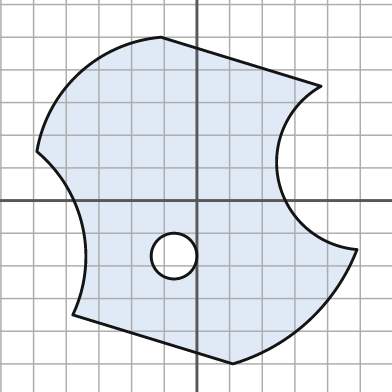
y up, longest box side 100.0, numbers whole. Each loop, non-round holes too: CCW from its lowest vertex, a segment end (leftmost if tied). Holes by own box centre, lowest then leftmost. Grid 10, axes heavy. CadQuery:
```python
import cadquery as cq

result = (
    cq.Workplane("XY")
    .moveTo(11.0, -50.0)
    .threePointArc((34.0, -37.0), (49.0, -15.0))
    .threePointArc((25.0, 6.0), (38.0, 35.0))
    .lineTo(-11.0, 50.0)
    .threePointArc((-36.0, 39.0), (-49.0, 15.0))
    .threePointArc((-35.0, -8.0), (-38.0, -35.0))
    .close()
    .moveTo(-7.0, -17.0)
    .circle(7.0)
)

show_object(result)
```